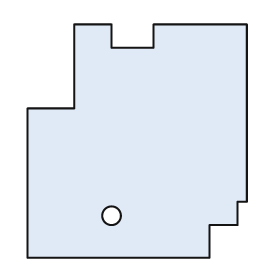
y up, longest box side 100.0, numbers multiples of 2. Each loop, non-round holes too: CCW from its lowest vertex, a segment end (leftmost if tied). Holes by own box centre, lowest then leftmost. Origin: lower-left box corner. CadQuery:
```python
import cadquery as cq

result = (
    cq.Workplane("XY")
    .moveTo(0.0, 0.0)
    .lineTo(78.0, 0.0)
    .lineTo(78.0, 14.0)
    .lineTo(90.0, 14.0)
    .lineTo(90.0, 24.0)
    .lineTo(94.0, 24.0)
    .lineTo(94.0, 100.0)
    .lineTo(54.0, 100.0)
    .lineTo(54.0, 90.0)
    .lineTo(36.0, 90.0)
    .lineTo(36.0, 100.0)
    .lineTo(20.0, 100.0)
    .lineTo(20.0, 64.0)
    .lineTo(0.0, 64.0)
    .close()
    .moveTo(36.0, 18.0)
    .circle(4.0)
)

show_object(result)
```